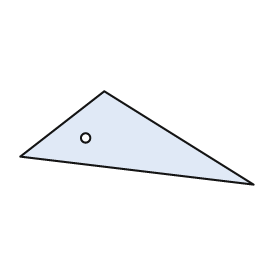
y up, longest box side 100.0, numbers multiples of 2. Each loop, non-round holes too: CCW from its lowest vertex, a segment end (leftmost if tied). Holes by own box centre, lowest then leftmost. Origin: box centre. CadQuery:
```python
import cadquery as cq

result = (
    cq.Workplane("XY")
    .moveTo(50.0, -20.0)
    .lineTo(-14.0, 20.0)
    .lineTo(-50.0, -8.0)
    .close()
    .moveTo(-22.0, 0.0)
    .circle(2.0)
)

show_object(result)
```